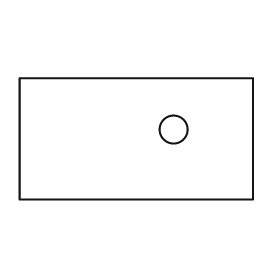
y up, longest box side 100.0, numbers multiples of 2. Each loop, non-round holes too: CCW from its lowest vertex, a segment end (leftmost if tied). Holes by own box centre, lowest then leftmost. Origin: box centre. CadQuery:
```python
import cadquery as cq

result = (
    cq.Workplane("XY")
    .moveTo(-50.0, -26.0)
    .lineTo(50.0, -26.0)
    .lineTo(50.0, 26.0)
    .lineTo(-50.0, 26.0)
    .close()
    .moveTo(16.0, 4.0)
    .circle(6.0)
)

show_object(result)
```